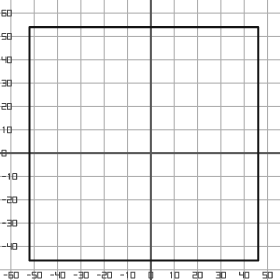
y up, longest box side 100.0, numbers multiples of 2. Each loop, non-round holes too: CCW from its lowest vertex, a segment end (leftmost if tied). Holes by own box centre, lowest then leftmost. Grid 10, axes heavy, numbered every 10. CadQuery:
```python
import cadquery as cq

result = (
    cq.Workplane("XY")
    .moveTo(-52.0, -46.0)
    .lineTo(46.0, -46.0)
    .lineTo(46.0, 54.0)
    .lineTo(-52.0, 54.0)
    .close()
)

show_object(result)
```